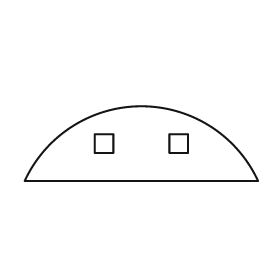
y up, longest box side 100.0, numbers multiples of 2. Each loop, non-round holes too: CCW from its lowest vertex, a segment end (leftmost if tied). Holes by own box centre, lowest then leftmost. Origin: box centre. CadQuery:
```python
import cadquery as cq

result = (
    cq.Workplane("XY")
    .moveTo(-50.0, -16.0)
    .lineTo(50.0, -16.0)
    .threePointArc((0.0, 16.0), (-50.0, -16.0))
    .close()
    .moveTo(-20.0, -4.0)
    .lineTo(-12.0, -4.0)
    .lineTo(-12.0, 4.0)
    .lineTo(-20.0, 4.0)
    .close()
    .moveTo(12.0, -4.0)
    .lineTo(20.0, -4.0)
    .lineTo(20.0, 4.0)
    .lineTo(12.0, 4.0)
    .close()
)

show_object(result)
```